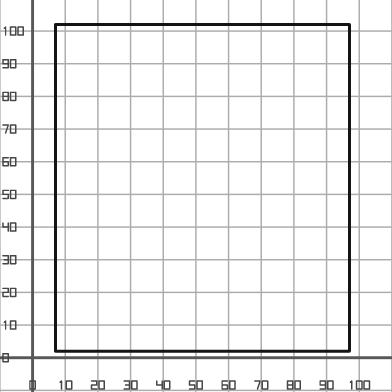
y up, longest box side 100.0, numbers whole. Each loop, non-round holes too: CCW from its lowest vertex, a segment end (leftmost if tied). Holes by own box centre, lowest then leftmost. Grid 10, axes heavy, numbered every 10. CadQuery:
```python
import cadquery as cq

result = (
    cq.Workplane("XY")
    .moveTo(7.0, 2.0)
    .lineTo(97.0, 2.0)
    .lineTo(97.0, 102.0)
    .lineTo(7.0, 102.0)
    .close()
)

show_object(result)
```